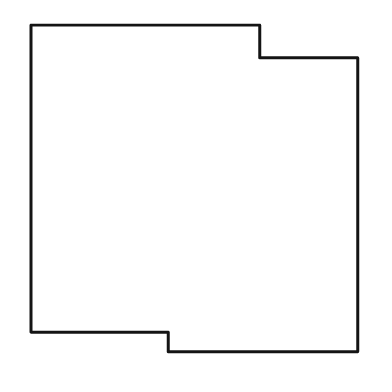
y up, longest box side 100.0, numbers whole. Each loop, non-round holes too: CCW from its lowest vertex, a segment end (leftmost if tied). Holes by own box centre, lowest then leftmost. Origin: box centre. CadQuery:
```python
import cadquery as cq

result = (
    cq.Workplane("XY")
    .moveTo(-8.0, -50.0)
    .lineTo(50.0, -50.0)
    .lineTo(50.0, 40.0)
    .lineTo(20.0, 40.0)
    .lineTo(20.0, 50.0)
    .lineTo(-50.0, 50.0)
    .lineTo(-50.0, -44.0)
    .lineTo(-8.0, -44.0)
    .close()
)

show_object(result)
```